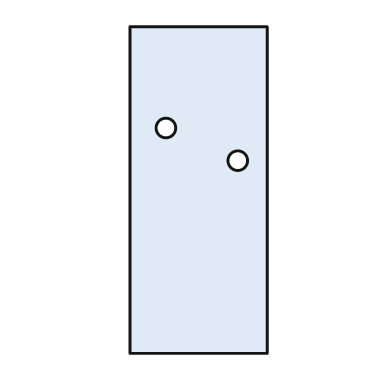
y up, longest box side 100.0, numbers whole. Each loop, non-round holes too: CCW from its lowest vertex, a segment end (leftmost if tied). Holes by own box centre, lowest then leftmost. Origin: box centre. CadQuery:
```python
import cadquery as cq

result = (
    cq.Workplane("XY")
    .moveTo(-21.0, -50.0)
    .lineTo(21.0, -50.0)
    .lineTo(21.0, 50.0)
    .lineTo(-21.0, 50.0)
    .close()
    .moveTo(12.0, 9.0)
    .circle(3.0)
    .moveTo(-10.0, 19.0)
    .circle(3.0)
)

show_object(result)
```